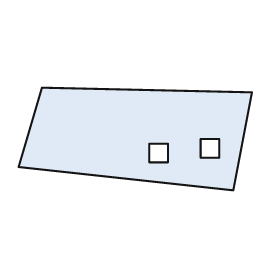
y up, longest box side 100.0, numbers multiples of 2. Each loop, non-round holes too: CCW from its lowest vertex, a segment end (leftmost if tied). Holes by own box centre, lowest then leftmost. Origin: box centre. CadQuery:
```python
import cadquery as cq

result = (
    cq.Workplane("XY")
    .moveTo(42.0, -22.0)
    .lineTo(50.0, 20.0)
    .lineTo(-40.0, 22.0)
    .lineTo(-50.0, -12.0)
    .close()
    .moveTo(6.0, -10.0)
    .lineTo(14.0, -10.0)
    .lineTo(14.0, -2.0)
    .lineTo(6.0, -2.0)
    .close()
    .moveTo(28.0, -8.0)
    .lineTo(36.0, -8.0)
    .lineTo(36.0, 0.0)
    .lineTo(28.0, 0.0)
    .close()
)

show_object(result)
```